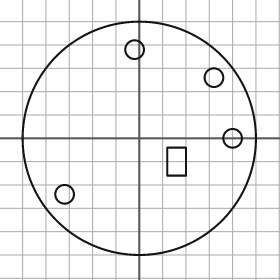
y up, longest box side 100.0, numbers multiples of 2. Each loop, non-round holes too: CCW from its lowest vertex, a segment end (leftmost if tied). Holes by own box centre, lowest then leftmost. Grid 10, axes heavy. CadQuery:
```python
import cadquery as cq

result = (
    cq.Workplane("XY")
    .moveTo(0.0, 0.0)
    .circle(50.0)
    .moveTo(-32.0, -24.0)
    .circle(4.0)
    .moveTo(12.0, -16.0)
    .lineTo(20.0, -16.0)
    .lineTo(20.0, -4.0)
    .lineTo(12.0, -4.0)
    .close()
    .moveTo(40.0, 0.0)
    .circle(4.0)
    .moveTo(32.0, 26.0)
    .circle(4.0)
    .moveTo(-2.0, 38.0)
    .circle(4.0)
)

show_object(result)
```